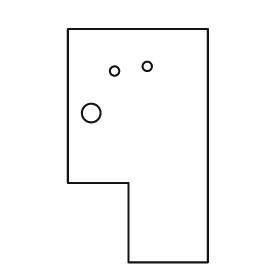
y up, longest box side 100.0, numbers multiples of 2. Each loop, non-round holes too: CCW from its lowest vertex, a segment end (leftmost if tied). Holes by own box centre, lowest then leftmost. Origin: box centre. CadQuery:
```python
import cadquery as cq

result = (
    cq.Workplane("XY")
    .moveTo(-4.0, -50.0)
    .lineTo(30.0, -50.0)
    .lineTo(30.0, 50.0)
    .lineTo(-30.0, 50.0)
    .lineTo(-30.0, -16.0)
    .lineTo(-4.0, -16.0)
    .close()
    .moveTo(-20.0, 14.0)
    .circle(4.0)
    .moveTo(-10.0, 32.0)
    .circle(2.0)
    .moveTo(4.0, 34.0)
    .circle(2.0)
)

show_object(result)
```